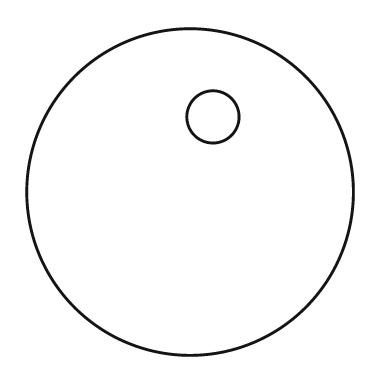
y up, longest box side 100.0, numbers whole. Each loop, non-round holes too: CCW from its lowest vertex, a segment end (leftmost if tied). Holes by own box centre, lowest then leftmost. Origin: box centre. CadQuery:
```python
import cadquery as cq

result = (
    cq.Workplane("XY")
    .moveTo(0.0, 0.0)
    .circle(50.0)
    .moveTo(7.0, 23.0)
    .circle(8.0)
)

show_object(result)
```